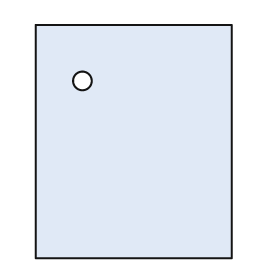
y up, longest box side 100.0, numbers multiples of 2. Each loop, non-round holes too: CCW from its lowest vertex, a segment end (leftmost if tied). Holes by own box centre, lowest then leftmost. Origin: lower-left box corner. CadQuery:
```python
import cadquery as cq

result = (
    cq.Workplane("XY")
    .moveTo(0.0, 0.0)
    .lineTo(84.0, 0.0)
    .lineTo(84.0, 100.0)
    .lineTo(0.0, 100.0)
    .close()
    .moveTo(20.0, 76.0)
    .circle(4.0)
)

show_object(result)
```